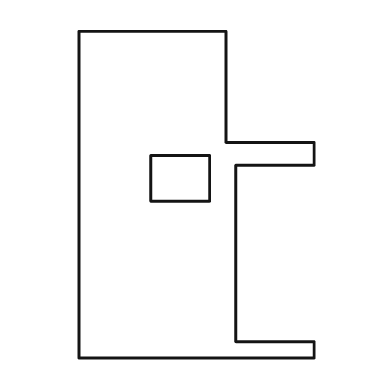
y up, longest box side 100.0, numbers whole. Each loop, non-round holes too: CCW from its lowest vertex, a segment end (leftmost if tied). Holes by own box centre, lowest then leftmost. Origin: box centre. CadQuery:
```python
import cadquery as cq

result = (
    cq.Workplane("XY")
    .moveTo(-36.0, -50.0)
    .lineTo(36.0, -50.0)
    .lineTo(36.0, -45.0)
    .lineTo(12.0, -45.0)
    .lineTo(12.0, 9.0)
    .lineTo(36.0, 9.0)
    .lineTo(36.0, 16.0)
    .lineTo(9.0, 16.0)
    .lineTo(9.0, 50.0)
    .lineTo(-36.0, 50.0)
    .close()
    .moveTo(-14.0, -2.0)
    .lineTo(4.0, -2.0)
    .lineTo(4.0, 12.0)
    .lineTo(-14.0, 12.0)
    .close()
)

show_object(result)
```